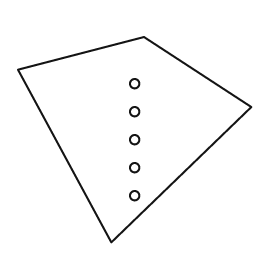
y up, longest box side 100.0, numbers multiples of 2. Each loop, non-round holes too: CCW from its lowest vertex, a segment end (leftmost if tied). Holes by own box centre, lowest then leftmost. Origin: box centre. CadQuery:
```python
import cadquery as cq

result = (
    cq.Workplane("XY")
    .moveTo(-10.0, -44.0)
    .lineTo(50.0, 14.0)
    .lineTo(4.0, 44.0)
    .lineTo(-50.0, 30.0)
    .close()
    .moveTo(0.0, -24.0)
    .circle(2.0)
    .moveTo(0.0, -12.0)
    .circle(2.0)
    .moveTo(0.0, 0.0)
    .circle(2.0)
    .moveTo(0.0, 12.0)
    .circle(2.0)
    .moveTo(0.0, 24.0)
    .circle(2.0)
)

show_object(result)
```